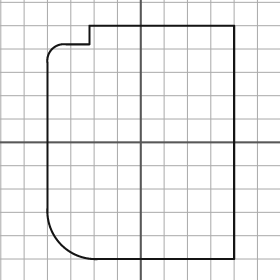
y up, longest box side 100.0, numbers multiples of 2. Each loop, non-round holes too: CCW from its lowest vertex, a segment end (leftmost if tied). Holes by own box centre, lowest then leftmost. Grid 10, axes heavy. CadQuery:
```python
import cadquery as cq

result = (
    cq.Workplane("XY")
    .moveTo(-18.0, -50.0)
    .lineTo(40.0, -50.0)
    .lineTo(40.0, 50.0)
    .lineTo(-22.0, 50.0)
    .lineTo(-22.0, 42.0)
    .lineTo(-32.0, 42.0)
    .threePointArc((-38.0, 40.0), (-40.0, 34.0))
    .lineTo(-40.0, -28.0)
    .threePointArc((-34.0, -44.0), (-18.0, -50.0))
    .close()
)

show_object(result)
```